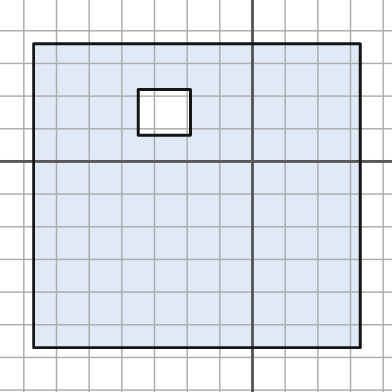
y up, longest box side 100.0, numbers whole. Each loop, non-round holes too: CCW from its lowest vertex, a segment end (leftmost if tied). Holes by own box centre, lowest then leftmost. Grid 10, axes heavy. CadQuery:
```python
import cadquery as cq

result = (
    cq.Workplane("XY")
    .moveTo(-67.0, -57.0)
    .lineTo(33.0, -57.0)
    .lineTo(33.0, 36.0)
    .lineTo(-67.0, 36.0)
    .close()
    .moveTo(-35.0, 8.0)
    .lineTo(-19.0, 8.0)
    .lineTo(-19.0, 22.0)
    .lineTo(-35.0, 22.0)
    .close()
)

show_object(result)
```